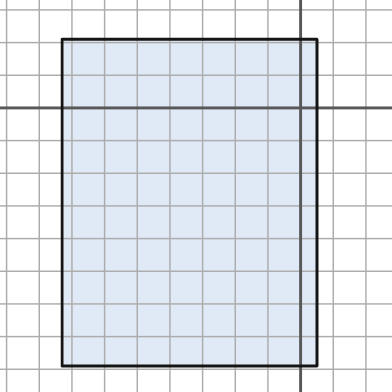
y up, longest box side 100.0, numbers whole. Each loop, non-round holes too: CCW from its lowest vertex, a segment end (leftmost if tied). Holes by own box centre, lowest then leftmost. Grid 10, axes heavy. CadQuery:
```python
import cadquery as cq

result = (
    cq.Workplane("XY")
    .moveTo(-73.0, -79.0)
    .lineTo(5.0, -79.0)
    .lineTo(5.0, 21.0)
    .lineTo(-73.0, 21.0)
    .close()
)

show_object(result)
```